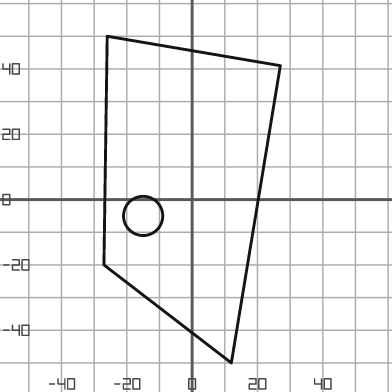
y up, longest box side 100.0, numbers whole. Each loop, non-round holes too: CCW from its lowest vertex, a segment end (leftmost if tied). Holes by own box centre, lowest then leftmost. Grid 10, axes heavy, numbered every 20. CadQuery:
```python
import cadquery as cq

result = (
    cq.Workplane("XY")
    .moveTo(12.0, -50.0)
    .lineTo(27.0, 41.0)
    .lineTo(-26.0, 50.0)
    .lineTo(-27.0, -20.0)
    .close()
    .moveTo(-15.0, -5.0)
    .circle(6.0)
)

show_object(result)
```